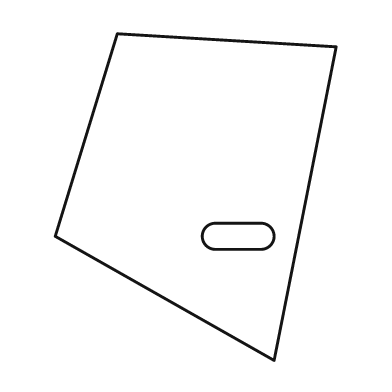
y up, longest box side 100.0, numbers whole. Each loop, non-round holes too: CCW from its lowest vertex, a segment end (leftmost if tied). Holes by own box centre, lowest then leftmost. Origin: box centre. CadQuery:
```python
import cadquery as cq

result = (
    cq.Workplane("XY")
    .moveTo(24.0, -50.0)
    .lineTo(43.0, 46.0)
    .lineTo(-24.0, 50.0)
    .lineTo(-43.0, -12.0)
    .close()
    .moveTo(6.0, -16.0)
    .lineTo(20.0, -16.0)
    .threePointArc((24.0, -12.0), (20.0, -8.0))
    .lineTo(6.0, -8.0)
    .threePointArc((2.0, -12.0), (6.0, -16.0))
    .close()
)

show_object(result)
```